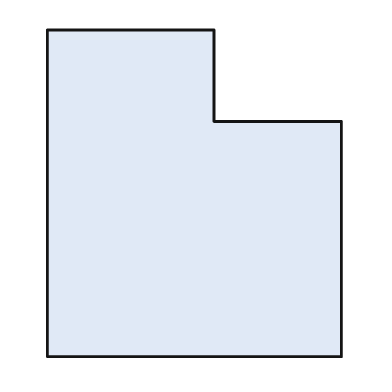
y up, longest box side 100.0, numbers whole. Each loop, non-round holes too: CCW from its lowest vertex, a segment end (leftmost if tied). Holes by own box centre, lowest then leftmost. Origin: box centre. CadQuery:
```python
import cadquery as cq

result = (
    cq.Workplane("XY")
    .moveTo(-45.0, -50.0)
    .lineTo(45.0, -50.0)
    .lineTo(45.0, 22.0)
    .lineTo(6.0, 22.0)
    .lineTo(6.0, 50.0)
    .lineTo(-45.0, 50.0)
    .close()
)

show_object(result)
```